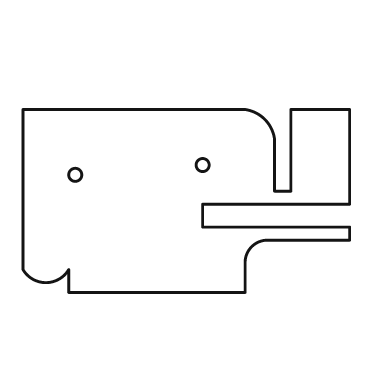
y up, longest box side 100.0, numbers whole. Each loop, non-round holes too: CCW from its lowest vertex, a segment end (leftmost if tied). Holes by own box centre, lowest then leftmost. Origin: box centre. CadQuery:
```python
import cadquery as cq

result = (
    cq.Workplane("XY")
    .moveTo(-36.0, -28.0)
    .lineTo(18.0, -28.0)
    .lineTo(18.0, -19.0)
    .threePointArc((20.0, -14.0), (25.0, -12.0))
    .lineTo(50.0, -12.0)
    .lineTo(50.0, -8.0)
    .lineTo(5.0, -8.0)
    .lineTo(5.0, -1.0)
    .lineTo(50.0, -1.0)
    .lineTo(50.0, 28.0)
    .lineTo(32.0, 28.0)
    .lineTo(32.0, 3.0)
    .lineTo(27.0, 3.0)
    .lineTo(27.0, 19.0)
    .threePointArc((24.0, 25.0), (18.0, 28.0))
    .lineTo(-50.0, 28.0)
    .lineTo(-50.0, -21.0)
    .threePointArc((-43.0, -25.0), (-36.0, -21.0))
    .close()
    .moveTo(-34.0, 8.0)
    .circle(2.0)
    .moveTo(5.0, 11.0)
    .circle(2.0)
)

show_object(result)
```